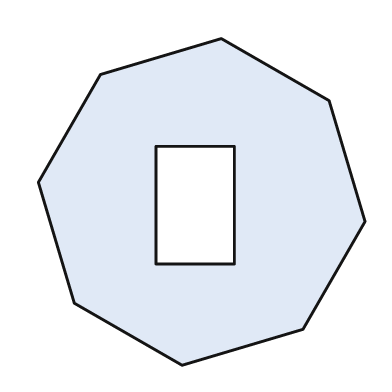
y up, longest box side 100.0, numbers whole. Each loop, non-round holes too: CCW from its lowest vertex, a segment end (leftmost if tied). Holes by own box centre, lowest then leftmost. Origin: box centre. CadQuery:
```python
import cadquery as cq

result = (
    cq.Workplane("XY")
    .moveTo(-6.0, -50.0)
    .lineTo(31.0, -39.0)
    .lineTo(50.0, -6.0)
    .lineTo(39.0, 31.0)
    .lineTo(6.0, 50.0)
    .lineTo(-31.0, 39.0)
    .lineTo(-50.0, 6.0)
    .lineTo(-39.0, -31.0)
    .close()
    .moveTo(-14.0, -19.0)
    .lineTo(10.0, -19.0)
    .lineTo(10.0, 17.0)
    .lineTo(-14.0, 17.0)
    .close()
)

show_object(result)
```